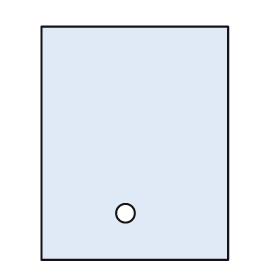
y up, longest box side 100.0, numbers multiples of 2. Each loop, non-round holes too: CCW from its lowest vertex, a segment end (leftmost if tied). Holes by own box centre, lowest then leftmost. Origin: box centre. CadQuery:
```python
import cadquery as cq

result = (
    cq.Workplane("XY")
    .moveTo(-40.0, -50.0)
    .lineTo(40.0, -50.0)
    .lineTo(40.0, 50.0)
    .lineTo(-40.0, 50.0)
    .close()
    .moveTo(-4.0, -30.0)
    .circle(4.0)
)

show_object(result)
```